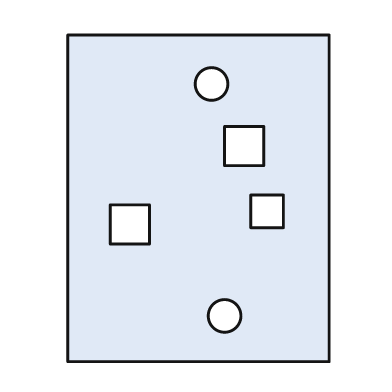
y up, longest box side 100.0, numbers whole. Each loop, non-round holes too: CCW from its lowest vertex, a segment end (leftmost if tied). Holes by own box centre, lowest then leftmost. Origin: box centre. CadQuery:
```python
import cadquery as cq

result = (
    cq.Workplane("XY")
    .moveTo(-40.0, -50.0)
    .lineTo(40.0, -50.0)
    .lineTo(40.0, 50.0)
    .lineTo(-40.0, 50.0)
    .close()
    .moveTo(8.0, -36.0)
    .circle(5.0)
    .moveTo(-27.0, -14.0)
    .lineTo(-15.0, -14.0)
    .lineTo(-15.0, -2.0)
    .lineTo(-27.0, -2.0)
    .close()
    .moveTo(16.0, -9.0)
    .lineTo(26.0, -9.0)
    .lineTo(26.0, 1.0)
    .lineTo(16.0, 1.0)
    .close()
    .moveTo(8.0, 10.0)
    .lineTo(20.0, 10.0)
    .lineTo(20.0, 22.0)
    .lineTo(8.0, 22.0)
    .close()
    .moveTo(4.0, 35.0)
    .circle(5.0)
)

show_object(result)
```